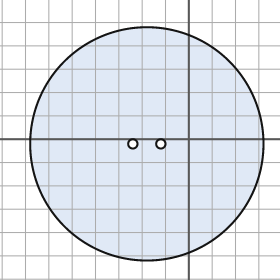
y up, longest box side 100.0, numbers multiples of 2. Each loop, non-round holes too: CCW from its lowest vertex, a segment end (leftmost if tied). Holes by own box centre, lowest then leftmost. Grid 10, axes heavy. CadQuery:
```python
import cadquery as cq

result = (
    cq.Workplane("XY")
    .moveTo(-18.0, -2.0)
    .circle(50.0)
    .moveTo(-24.0, -2.0)
    .circle(2.0)
    .moveTo(-12.0, -2.0)
    .circle(2.0)
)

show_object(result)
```